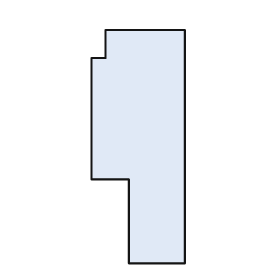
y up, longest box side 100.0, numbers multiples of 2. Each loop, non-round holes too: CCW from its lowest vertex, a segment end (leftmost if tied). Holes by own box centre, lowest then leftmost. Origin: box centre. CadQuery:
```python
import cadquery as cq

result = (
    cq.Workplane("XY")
    .moveTo(-4.0, -50.0)
    .lineTo(20.0, -50.0)
    .lineTo(20.0, 50.0)
    .lineTo(-14.0, 50.0)
    .lineTo(-14.0, 38.0)
    .lineTo(-20.0, 38.0)
    .lineTo(-20.0, -14.0)
    .lineTo(-4.0, -14.0)
    .close()
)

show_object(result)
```